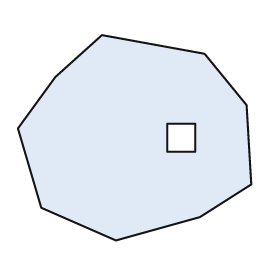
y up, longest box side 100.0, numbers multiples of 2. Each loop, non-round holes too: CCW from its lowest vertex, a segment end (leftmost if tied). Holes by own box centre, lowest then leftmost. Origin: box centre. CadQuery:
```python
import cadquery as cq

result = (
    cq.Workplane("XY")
    .moveTo(-8.0, -44.0)
    .lineTo(28.0, -34.0)
    .lineTo(50.0, -20.0)
    .lineTo(48.0, 14.0)
    .lineTo(30.0, 36.0)
    .lineTo(-14.0, 44.0)
    .lineTo(-34.0, 26.0)
    .lineTo(-50.0, 4.0)
    .lineTo(-40.0, -30.0)
    .close()
    .moveTo(14.0, -6.0)
    .lineTo(26.0, -6.0)
    .lineTo(26.0, 6.0)
    .lineTo(14.0, 6.0)
    .close()
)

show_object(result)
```